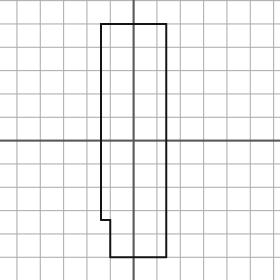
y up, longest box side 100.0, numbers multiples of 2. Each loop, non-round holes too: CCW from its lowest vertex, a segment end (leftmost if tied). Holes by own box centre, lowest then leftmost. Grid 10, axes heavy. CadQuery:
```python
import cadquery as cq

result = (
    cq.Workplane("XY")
    .moveTo(-10.0, -50.0)
    .lineTo(14.0, -50.0)
    .lineTo(14.0, 50.0)
    .lineTo(-14.0, 50.0)
    .lineTo(-14.0, -34.0)
    .lineTo(-10.0, -34.0)
    .close()
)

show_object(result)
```